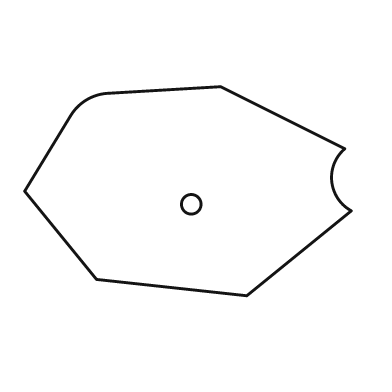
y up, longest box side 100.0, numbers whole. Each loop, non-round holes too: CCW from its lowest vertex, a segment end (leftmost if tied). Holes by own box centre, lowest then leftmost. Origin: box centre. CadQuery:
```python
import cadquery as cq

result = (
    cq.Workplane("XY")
    .moveTo(18.0, -32.0)
    .lineTo(50.0, -6.0)
    .threePointArc((44.0, 3.0), (48.0, 13.0))
    .lineTo(10.0, 32.0)
    .lineTo(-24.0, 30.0)
    .threePointArc((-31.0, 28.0), (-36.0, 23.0))
    .lineTo(-50.0, 0.0)
    .lineTo(-28.0, -27.0)
    .close()
    .moveTo(1.0, -4.0)
    .circle(3.0)
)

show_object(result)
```